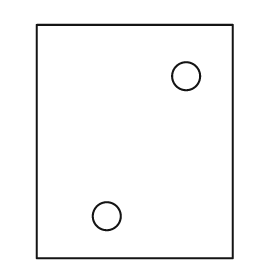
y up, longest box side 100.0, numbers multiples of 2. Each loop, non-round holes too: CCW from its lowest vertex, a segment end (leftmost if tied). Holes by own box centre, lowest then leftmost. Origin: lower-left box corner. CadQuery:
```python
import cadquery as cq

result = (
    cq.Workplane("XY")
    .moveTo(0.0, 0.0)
    .lineTo(84.0, 0.0)
    .lineTo(84.0, 100.0)
    .lineTo(0.0, 100.0)
    .close()
    .moveTo(30.0, 18.0)
    .circle(6.0)
    .moveTo(64.0, 78.0)
    .circle(6.0)
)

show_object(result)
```